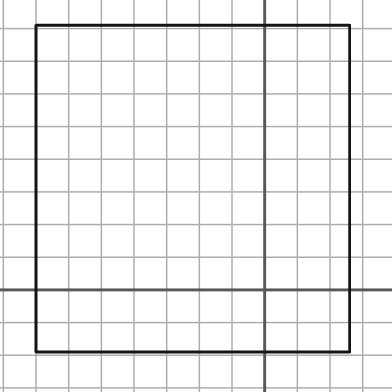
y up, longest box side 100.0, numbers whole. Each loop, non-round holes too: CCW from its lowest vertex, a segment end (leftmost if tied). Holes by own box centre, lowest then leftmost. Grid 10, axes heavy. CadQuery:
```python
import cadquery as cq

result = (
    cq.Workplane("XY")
    .moveTo(-70.0, -19.0)
    .lineTo(26.0, -19.0)
    .lineTo(26.0, 81.0)
    .lineTo(-70.0, 81.0)
    .close()
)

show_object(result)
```